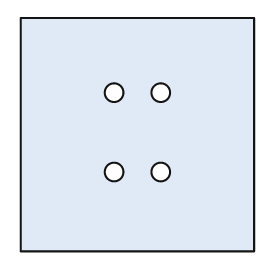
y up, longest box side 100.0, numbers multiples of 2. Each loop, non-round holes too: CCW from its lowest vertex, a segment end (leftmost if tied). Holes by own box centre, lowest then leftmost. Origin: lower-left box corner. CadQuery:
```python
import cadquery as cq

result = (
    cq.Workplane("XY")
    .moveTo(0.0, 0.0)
    .lineTo(100.0, 0.0)
    .lineTo(100.0, 100.0)
    .lineTo(0.0, 100.0)
    .close()
    .moveTo(40.0, 34.0)
    .circle(4.0)
    .moveTo(60.0, 34.0)
    .circle(4.0)
    .moveTo(40.0, 68.0)
    .circle(4.0)
    .moveTo(60.0, 68.0)
    .circle(4.0)
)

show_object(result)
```